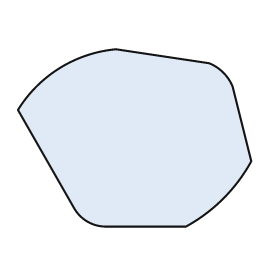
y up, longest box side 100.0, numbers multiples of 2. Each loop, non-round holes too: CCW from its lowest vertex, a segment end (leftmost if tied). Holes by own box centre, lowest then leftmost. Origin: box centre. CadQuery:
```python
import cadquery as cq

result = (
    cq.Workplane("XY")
    .moveTo(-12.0, -38.0)
    .lineTo(22.0, -38.0)
    .threePointArc((38.0, -26.0), (50.0, -10.0))
    .lineTo(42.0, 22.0)
    .threePointArc((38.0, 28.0), (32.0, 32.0))
    .lineTo(-8.0, 38.0)
    .threePointArc((-32.0, 30.0), (-50.0, 12.0))
    .lineTo(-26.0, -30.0)
    .threePointArc((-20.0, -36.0), (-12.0, -38.0))
    .close()
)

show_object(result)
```